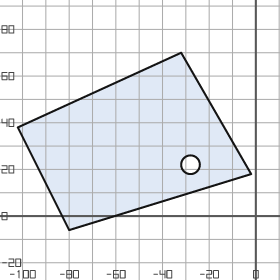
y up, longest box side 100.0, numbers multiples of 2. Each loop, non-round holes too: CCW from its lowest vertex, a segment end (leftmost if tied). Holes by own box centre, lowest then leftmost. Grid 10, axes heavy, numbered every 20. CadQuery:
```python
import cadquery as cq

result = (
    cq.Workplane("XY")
    .moveTo(-80.0, -6.0)
    .lineTo(-2.0, 18.0)
    .lineTo(-32.0, 70.0)
    .lineTo(-102.0, 38.0)
    .close()
    .moveTo(-28.0, 22.0)
    .circle(4.0)
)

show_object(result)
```